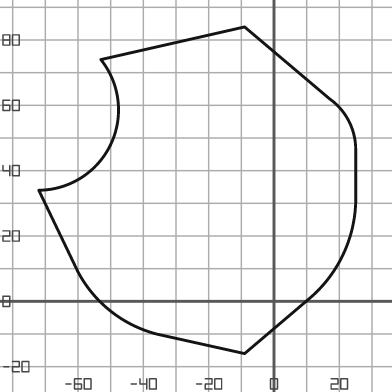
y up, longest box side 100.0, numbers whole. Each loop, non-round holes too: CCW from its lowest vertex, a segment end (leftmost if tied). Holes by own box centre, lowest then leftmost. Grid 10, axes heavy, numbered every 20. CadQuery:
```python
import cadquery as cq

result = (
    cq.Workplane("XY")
    .moveTo(-9.0, -16.0)
    .lineTo(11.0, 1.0)
    .threePointArc((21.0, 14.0), (25.0, 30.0))
    .lineTo(25.0, 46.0)
    .threePointArc((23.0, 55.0), (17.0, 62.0))
    .lineTo(-9.0, 84.0)
    .lineTo(-53.0, 74.0)
    .threePointArc((-50.0, 48.0), (-72.0, 34.0))
    .lineTo(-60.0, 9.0)
    .threePointArc((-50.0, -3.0), (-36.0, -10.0))
    .close()
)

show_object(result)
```